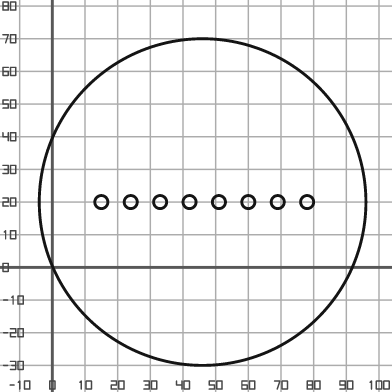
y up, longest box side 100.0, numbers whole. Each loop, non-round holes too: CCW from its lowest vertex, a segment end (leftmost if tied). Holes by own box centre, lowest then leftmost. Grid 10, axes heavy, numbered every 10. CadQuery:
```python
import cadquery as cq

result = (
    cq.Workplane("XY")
    .moveTo(46.0, 20.0)
    .circle(50.0)
    .moveTo(15.0, 20.0)
    .circle(2.0)
    .moveTo(24.0, 20.0)
    .circle(2.0)
    .moveTo(33.0, 20.0)
    .circle(2.0)
    .moveTo(42.0, 20.0)
    .circle(2.0)
    .moveTo(51.0, 20.0)
    .circle(2.0)
    .moveTo(60.0, 20.0)
    .circle(2.0)
    .moveTo(69.0, 20.0)
    .circle(2.0)
    .moveTo(78.0, 20.0)
    .circle(2.0)
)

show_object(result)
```